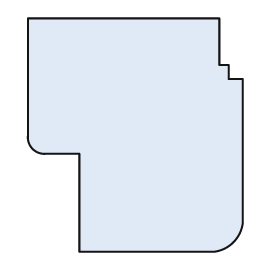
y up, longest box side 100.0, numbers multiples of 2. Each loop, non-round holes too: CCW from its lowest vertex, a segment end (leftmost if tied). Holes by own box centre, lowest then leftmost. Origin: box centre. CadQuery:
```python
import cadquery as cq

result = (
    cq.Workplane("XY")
    .moveTo(-24.0, -50.0)
    .lineTo(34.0, -50.0)
    .threePointArc((42.0, -46.0), (46.0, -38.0))
    .lineTo(46.0, 24.0)
    .lineTo(40.0, 24.0)
    .lineTo(40.0, 30.0)
    .lineTo(36.0, 30.0)
    .lineTo(36.0, 50.0)
    .lineTo(-46.0, 50.0)
    .lineTo(-46.0, 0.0)
    .threePointArc((-44.0, -6.0), (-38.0, -8.0))
    .lineTo(-24.0, -8.0)
    .close()
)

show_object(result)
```